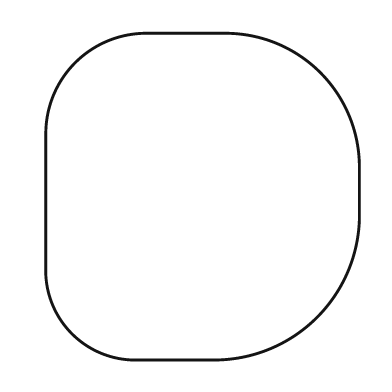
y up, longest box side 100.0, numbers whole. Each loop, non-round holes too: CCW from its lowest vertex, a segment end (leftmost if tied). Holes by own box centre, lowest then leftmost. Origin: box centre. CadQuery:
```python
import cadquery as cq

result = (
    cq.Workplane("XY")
    .moveTo(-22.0, -50.0)
    .lineTo(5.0, -50.0)
    .threePointArc((35.0, -37.0), (48.0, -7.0))
    .lineTo(48.0, 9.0)
    .threePointArc((36.0, 38.0), (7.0, 50.0))
    .lineTo(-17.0, 50.0)
    .threePointArc((-39.0, 41.0), (-48.0, 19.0))
    .lineTo(-48.0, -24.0)
    .threePointArc((-40.0, -42.0), (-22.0, -50.0))
    .close()
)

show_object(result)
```